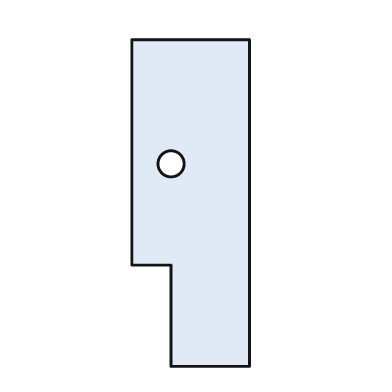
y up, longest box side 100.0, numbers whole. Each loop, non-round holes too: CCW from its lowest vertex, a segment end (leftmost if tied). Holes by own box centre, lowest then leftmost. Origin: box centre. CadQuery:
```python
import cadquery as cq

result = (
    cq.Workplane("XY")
    .moveTo(-6.0, -50.0)
    .lineTo(18.0, -50.0)
    .lineTo(18.0, 50.0)
    .lineTo(-18.0, 50.0)
    .lineTo(-18.0, -19.0)
    .lineTo(-6.0, -19.0)
    .close()
    .moveTo(-6.0, 12.0)
    .circle(4.0)
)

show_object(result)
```